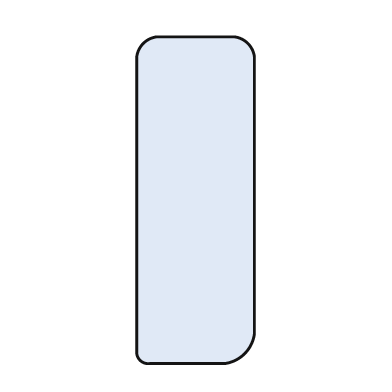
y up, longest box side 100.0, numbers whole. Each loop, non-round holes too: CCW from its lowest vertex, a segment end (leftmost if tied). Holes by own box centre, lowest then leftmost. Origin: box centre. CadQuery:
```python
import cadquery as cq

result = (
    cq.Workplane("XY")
    .moveTo(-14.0, -50.0)
    .lineTo(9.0, -50.0)
    .threePointArc((15.0, -47.0), (18.0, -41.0))
    .lineTo(18.0, 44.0)
    .threePointArc((16.0, 48.0), (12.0, 50.0))
    .lineTo(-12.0, 50.0)
    .threePointArc((-16.0, 48.0), (-18.0, 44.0))
    .lineTo(-18.0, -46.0)
    .threePointArc((-17.0, -49.0), (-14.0, -50.0))
    .close()
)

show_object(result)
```